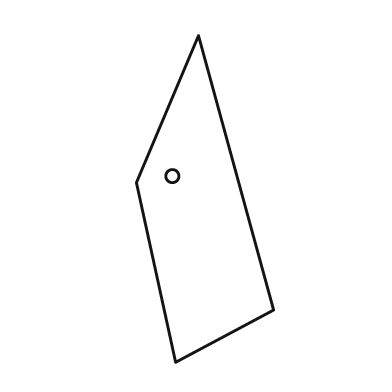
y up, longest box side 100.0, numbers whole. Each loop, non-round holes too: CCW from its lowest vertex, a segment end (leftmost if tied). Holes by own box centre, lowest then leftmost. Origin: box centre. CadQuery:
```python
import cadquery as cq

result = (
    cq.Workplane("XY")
    .moveTo(-9.0, -50.0)
    .lineTo(21.0, -34.0)
    .lineTo(-2.0, 50.0)
    .lineTo(-21.0, 5.0)
    .close()
    .moveTo(-10.0, 7.0)
    .circle(2.0)
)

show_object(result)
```